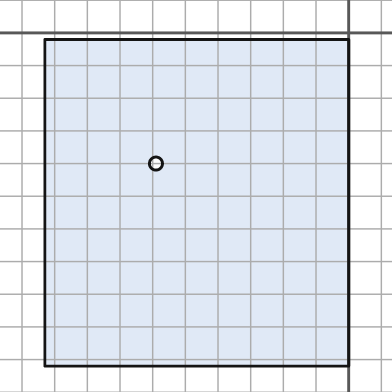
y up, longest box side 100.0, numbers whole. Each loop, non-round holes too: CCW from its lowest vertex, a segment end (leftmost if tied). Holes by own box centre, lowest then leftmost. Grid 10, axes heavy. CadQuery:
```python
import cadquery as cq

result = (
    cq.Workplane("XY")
    .moveTo(-93.0, -102.0)
    .lineTo(0.0, -102.0)
    .lineTo(0.0, -2.0)
    .lineTo(-93.0, -2.0)
    .close()
    .moveTo(-59.0, -40.0)
    .circle(2.0)
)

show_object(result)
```